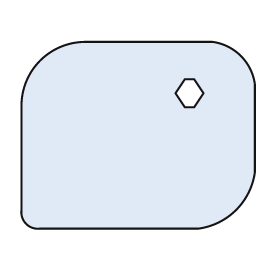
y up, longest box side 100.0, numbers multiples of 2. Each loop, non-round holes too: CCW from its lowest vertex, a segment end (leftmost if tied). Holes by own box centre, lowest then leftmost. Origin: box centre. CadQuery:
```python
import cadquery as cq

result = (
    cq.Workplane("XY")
    .moveTo(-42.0, -40.0)
    .lineTo(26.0, -40.0)
    .threePointArc((42.0, -32.0), (50.0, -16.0))
    .lineTo(50.0, 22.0)
    .threePointArc((44.0, 34.0), (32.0, 40.0))
    .lineTo(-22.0, 40.0)
    .threePointArc((-42.0, 32.0), (-50.0, 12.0))
    .lineTo(-50.0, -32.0)
    .threePointArc((-48.0, -38.0), (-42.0, -40.0))
    .close()
    .moveTo(20.0, 12.0)
    .lineTo(24.0, 12.0)
    .lineTo(28.0, 18.0)
    .lineTo(24.0, 24.0)
    .lineTo(20.0, 24.0)
    .lineTo(16.0, 18.0)
    .close()
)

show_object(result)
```